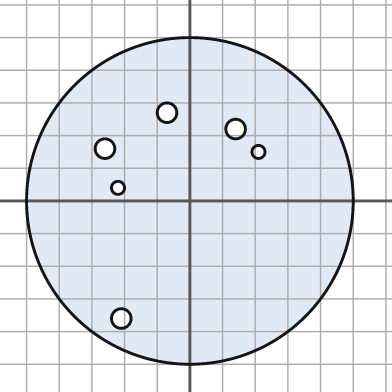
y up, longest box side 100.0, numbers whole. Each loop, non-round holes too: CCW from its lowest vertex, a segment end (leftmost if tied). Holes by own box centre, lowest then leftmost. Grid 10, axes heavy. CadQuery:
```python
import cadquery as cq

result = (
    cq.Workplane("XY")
    .moveTo(0.0, 0.0)
    .circle(50.0)
    .moveTo(-21.0, -36.0)
    .circle(3.0)
    .moveTo(-22.0, 4.0)
    .circle(2.0)
    .moveTo(21.0, 15.0)
    .circle(2.0)
    .moveTo(-26.0, 16.0)
    .circle(3.0)
    .moveTo(14.0, 22.0)
    .circle(3.0)
    .moveTo(-7.0, 27.0)
    .circle(3.0)
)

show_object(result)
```